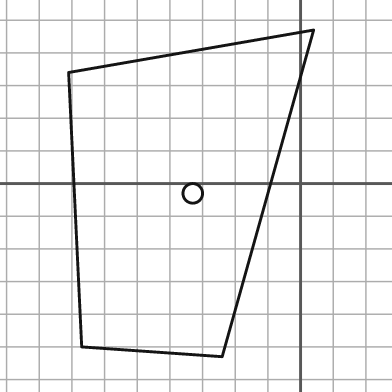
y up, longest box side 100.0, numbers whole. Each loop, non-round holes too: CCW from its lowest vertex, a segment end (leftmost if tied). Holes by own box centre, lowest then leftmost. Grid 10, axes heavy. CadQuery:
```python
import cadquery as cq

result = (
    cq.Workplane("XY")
    .moveTo(-24.0, -53.0)
    .lineTo(4.0, 47.0)
    .lineTo(-71.0, 34.0)
    .lineTo(-67.0, -50.0)
    .close()
    .moveTo(-33.0, -3.0)
    .circle(3.0)
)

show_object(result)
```